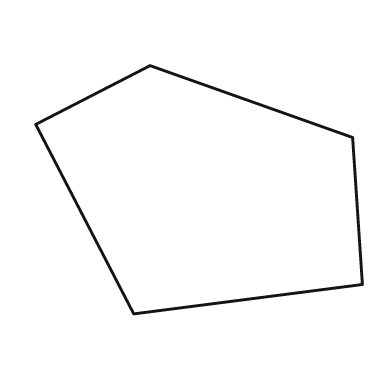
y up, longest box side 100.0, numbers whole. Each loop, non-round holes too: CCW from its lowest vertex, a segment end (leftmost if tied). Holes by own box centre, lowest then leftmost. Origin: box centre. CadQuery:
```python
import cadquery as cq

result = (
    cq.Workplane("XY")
    .moveTo(-20.0, -38.0)
    .lineTo(50.0, -29.0)
    .lineTo(47.0, 16.0)
    .lineTo(-15.0, 38.0)
    .lineTo(-50.0, 20.0)
    .close()
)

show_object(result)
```